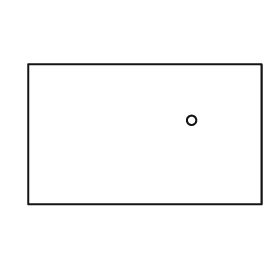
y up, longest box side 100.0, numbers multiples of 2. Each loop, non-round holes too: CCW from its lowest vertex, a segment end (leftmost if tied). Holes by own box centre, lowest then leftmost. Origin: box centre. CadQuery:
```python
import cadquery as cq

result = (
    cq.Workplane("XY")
    .moveTo(-50.0, -30.0)
    .lineTo(50.0, -30.0)
    .lineTo(50.0, 30.0)
    .lineTo(-50.0, 30.0)
    .close()
    .moveTo(20.0, 6.0)
    .circle(2.0)
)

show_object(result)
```